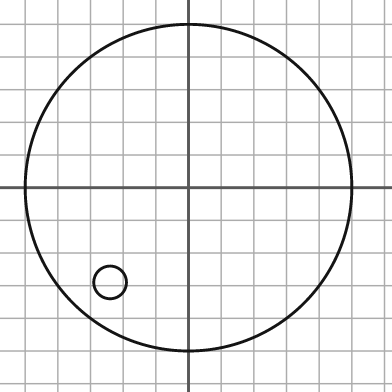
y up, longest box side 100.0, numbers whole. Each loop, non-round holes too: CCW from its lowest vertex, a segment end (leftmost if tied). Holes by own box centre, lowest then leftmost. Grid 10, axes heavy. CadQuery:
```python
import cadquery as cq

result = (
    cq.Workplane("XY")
    .moveTo(0.0, 0.0)
    .circle(50.0)
    .moveTo(-24.0, -29.0)
    .circle(5.0)
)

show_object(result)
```